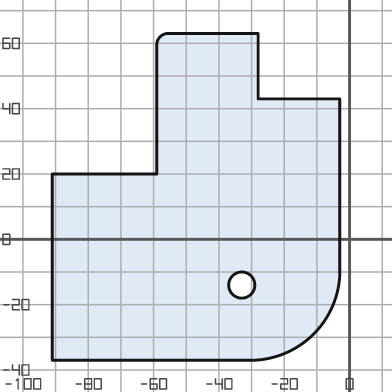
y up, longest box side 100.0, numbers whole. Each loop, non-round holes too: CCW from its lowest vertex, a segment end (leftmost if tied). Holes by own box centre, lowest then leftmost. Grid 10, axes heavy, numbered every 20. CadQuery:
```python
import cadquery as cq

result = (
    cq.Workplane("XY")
    .moveTo(-91.0, -37.0)
    .lineTo(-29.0, -37.0)
    .threePointArc((-11.0, -29.0), (-3.0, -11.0))
    .lineTo(-3.0, 43.0)
    .lineTo(-28.0, 43.0)
    .lineTo(-28.0, 63.0)
    .lineTo(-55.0, 63.0)
    .threePointArc((-58.0, 62.0), (-59.0, 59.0))
    .lineTo(-59.0, 20.0)
    .lineTo(-91.0, 20.0)
    .close()
    .moveTo(-33.0, -14.0)
    .circle(4.0)
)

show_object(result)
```